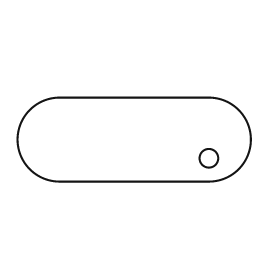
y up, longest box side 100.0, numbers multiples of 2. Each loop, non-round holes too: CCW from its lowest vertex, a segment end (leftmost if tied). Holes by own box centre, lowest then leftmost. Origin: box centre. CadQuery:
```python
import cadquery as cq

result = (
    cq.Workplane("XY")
    .moveTo(-32.0, -18.0)
    .lineTo(32.0, -18.0)
    .threePointArc((50.0, 0.0), (32.0, 18.0))
    .lineTo(-32.0, 18.0)
    .threePointArc((-50.0, 0.0), (-32.0, -18.0))
    .close()
    .moveTo(32.0, -8.0)
    .circle(4.0)
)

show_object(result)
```